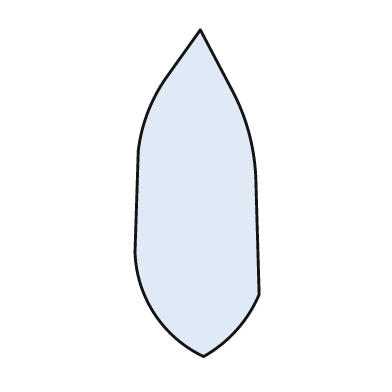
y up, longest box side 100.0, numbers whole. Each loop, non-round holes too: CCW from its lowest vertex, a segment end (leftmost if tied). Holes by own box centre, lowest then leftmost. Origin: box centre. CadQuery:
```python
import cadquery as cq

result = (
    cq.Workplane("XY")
    .moveTo(2.0, -50.0)
    .threePointArc((12.0, -42.0), (19.0, -31.0))
    .lineTo(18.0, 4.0)
    .threePointArc((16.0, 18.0), (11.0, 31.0))
    .lineTo(1.0, 50.0)
    .lineTo(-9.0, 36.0)
    .threePointArc((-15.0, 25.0), (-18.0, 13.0))
    .lineTo(-19.0, -18.0)
    .threePointArc((-13.0, -37.0), (2.0, -50.0))
    .close()
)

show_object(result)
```